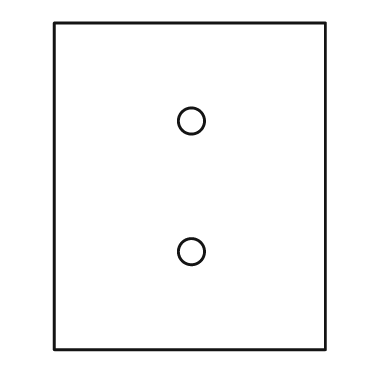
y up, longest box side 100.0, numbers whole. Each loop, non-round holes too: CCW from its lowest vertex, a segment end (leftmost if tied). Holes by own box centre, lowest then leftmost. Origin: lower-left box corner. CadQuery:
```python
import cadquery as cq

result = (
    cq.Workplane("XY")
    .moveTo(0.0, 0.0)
    .lineTo(83.0, 0.0)
    .lineTo(83.0, 100.0)
    .lineTo(0.0, 100.0)
    .close()
    .moveTo(42.0, 30.0)
    .circle(4.0)
    .moveTo(42.0, 70.0)
    .circle(4.0)
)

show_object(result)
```